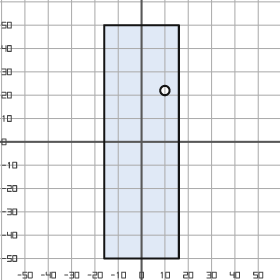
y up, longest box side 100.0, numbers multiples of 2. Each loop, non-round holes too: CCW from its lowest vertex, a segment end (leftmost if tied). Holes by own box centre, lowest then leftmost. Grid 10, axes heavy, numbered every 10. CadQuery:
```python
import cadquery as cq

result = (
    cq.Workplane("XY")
    .moveTo(-16.0, -50.0)
    .lineTo(16.0, -50.0)
    .lineTo(16.0, 50.0)
    .lineTo(-16.0, 50.0)
    .close()
    .moveTo(10.0, 22.0)
    .circle(2.0)
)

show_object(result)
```